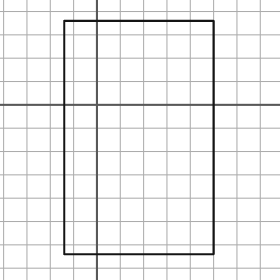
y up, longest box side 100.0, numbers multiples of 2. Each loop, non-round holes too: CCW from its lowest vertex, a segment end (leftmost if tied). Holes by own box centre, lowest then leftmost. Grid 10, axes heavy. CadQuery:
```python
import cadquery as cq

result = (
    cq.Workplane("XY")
    .moveTo(-14.0, -64.0)
    .lineTo(50.0, -64.0)
    .lineTo(50.0, 36.0)
    .lineTo(-14.0, 36.0)
    .close()
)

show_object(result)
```